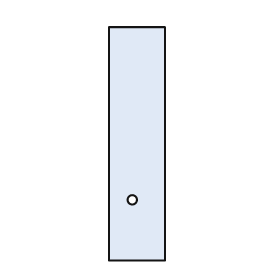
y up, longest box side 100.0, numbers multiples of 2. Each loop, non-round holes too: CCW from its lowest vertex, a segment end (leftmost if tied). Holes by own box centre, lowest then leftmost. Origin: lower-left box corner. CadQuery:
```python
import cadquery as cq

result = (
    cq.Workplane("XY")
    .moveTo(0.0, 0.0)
    .lineTo(24.0, 0.0)
    .lineTo(24.0, 100.0)
    .lineTo(0.0, 100.0)
    .close()
    .moveTo(10.0, 26.0)
    .circle(2.0)
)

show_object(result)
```